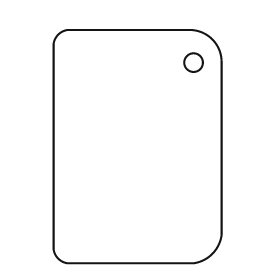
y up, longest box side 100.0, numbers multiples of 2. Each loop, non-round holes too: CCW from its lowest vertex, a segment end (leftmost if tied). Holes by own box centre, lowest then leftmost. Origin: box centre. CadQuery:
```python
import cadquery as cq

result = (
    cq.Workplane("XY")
    .moveTo(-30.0, -50.0)
    .lineTo(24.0, -50.0)
    .threePointArc((32.0, -46.0), (36.0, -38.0))
    .lineTo(36.0, 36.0)
    .threePointArc((32.0, 46.0), (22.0, 50.0))
    .lineTo(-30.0, 50.0)
    .threePointArc((-34.0, 48.0), (-36.0, 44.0))
    .lineTo(-36.0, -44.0)
    .threePointArc((-34.0, -48.0), (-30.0, -50.0))
    .close()
    .moveTo(24.0, 36.0)
    .circle(4.0)
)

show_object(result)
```